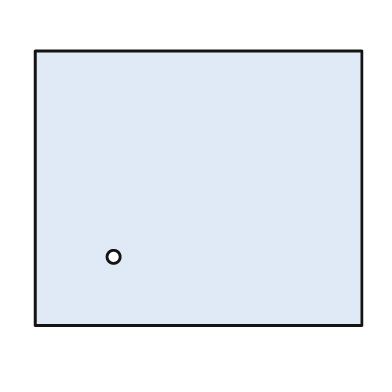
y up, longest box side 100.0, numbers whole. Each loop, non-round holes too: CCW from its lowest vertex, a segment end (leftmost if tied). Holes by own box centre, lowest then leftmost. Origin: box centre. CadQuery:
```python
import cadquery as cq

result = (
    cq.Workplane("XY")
    .moveTo(-50.0, -42.0)
    .lineTo(50.0, -42.0)
    .lineTo(50.0, 42.0)
    .lineTo(-50.0, 42.0)
    .close()
    .moveTo(-26.0, -21.0)
    .circle(2.0)
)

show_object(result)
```